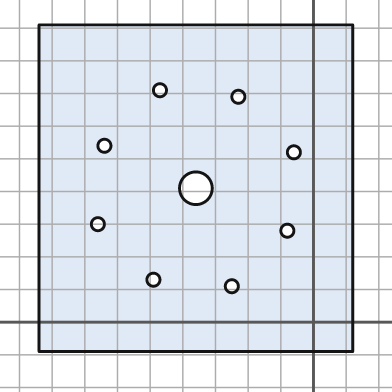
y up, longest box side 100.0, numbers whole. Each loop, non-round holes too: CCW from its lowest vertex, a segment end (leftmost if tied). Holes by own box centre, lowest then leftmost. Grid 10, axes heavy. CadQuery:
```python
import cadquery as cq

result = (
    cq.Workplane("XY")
    .moveTo(-84.0, -9.0)
    .lineTo(12.0, -9.0)
    .lineTo(12.0, 91.0)
    .lineTo(-84.0, 91.0)
    .close()
    .moveTo(-25.0, 11.0)
    .circle(2.0)
    .moveTo(-49.0, 13.0)
    .circle(2.0)
    .moveTo(-8.0, 28.0)
    .circle(2.0)
    .moveTo(-66.0, 30.0)
    .circle(2.0)
    .moveTo(-36.0, 41.0)
    .circle(5.0)
    .moveTo(-6.0, 52.0)
    .circle(2.0)
    .moveTo(-64.0, 54.0)
    .circle(2.0)
    .moveTo(-23.0, 69.0)
    .circle(2.0)
    .moveTo(-47.0, 71.0)
    .circle(2.0)
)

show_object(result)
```